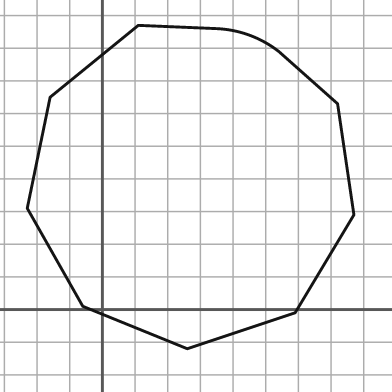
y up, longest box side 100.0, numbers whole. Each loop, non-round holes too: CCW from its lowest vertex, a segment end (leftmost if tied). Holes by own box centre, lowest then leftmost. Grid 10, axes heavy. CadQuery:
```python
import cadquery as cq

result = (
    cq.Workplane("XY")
    .moveTo(26.0, -12.0)
    .lineTo(59.0, -1.0)
    .lineTo(77.0, 29.0)
    .lineTo(72.0, 63.0)
    .lineTo(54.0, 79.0)
    .threePointArc((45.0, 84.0), (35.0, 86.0))
    .lineTo(11.0, 87.0)
    .lineTo(-16.0, 65.0)
    .lineTo(-23.0, 31.0)
    .lineTo(-6.0, 1.0)
    .close()
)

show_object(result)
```